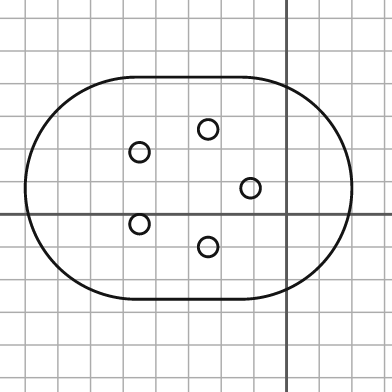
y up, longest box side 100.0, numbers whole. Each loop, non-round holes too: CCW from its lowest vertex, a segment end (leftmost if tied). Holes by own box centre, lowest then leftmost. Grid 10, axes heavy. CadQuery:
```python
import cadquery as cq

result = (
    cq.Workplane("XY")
    .moveTo(-46.0, -26.0)
    .lineTo(-14.0, -26.0)
    .threePointArc((20.0, 8.0), (-14.0, 42.0))
    .lineTo(-46.0, 42.0)
    .threePointArc((-80.0, 8.0), (-46.0, -26.0))
    .close()
    .moveTo(-24.0, -10.0)
    .circle(3.0)
    .moveTo(-45.0, -3.0)
    .circle(3.0)
    .moveTo(-11.0, 8.0)
    .circle(3.0)
    .moveTo(-45.0, 19.0)
    .circle(3.0)
    .moveTo(-24.0, 26.0)
    .circle(3.0)
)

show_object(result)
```